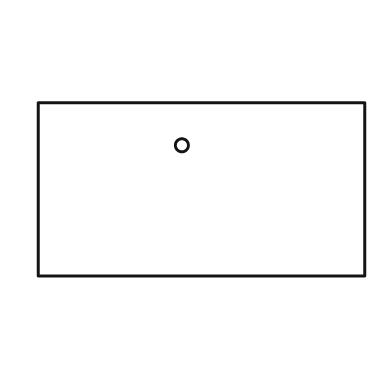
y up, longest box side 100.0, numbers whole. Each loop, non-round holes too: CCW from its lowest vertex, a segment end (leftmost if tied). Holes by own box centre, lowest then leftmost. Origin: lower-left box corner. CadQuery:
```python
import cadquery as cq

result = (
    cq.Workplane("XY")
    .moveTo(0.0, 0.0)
    .lineTo(100.0, 0.0)
    .lineTo(100.0, 53.0)
    .lineTo(0.0, 53.0)
    .close()
    .moveTo(44.0, 40.0)
    .circle(2.0)
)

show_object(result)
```